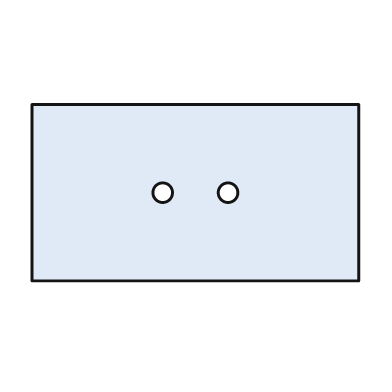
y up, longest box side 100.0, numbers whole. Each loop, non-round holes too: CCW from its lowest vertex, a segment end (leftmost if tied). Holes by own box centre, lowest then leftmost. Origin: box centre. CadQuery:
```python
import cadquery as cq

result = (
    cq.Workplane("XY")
    .moveTo(-50.0, -27.0)
    .lineTo(50.0, -27.0)
    .lineTo(50.0, 27.0)
    .lineTo(-50.0, 27.0)
    .close()
    .moveTo(-10.0, 0.0)
    .circle(3.0)
    .moveTo(10.0, 0.0)
    .circle(3.0)
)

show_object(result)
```